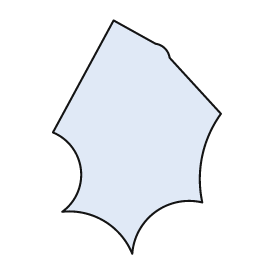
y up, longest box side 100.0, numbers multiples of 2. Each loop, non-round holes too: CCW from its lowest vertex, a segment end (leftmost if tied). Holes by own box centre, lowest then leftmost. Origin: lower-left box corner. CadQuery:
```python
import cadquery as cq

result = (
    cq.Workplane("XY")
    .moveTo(34.0, 0.0)
    .threePointArc((44.0, 18.0), (64.0, 22.0))
    .threePointArc((64.0, 42.0), (72.0, 60.0))
    .lineTo(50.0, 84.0)
    .threePointArc((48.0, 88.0), (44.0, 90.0))
    .lineTo(26.0, 100.0)
    .lineTo(0.0, 52.0)
    .threePointArc((12.0, 36.0), (4.0, 18.0))
    .threePointArc((22.0, 14.0), (34.0, 0.0))
    .close()
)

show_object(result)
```